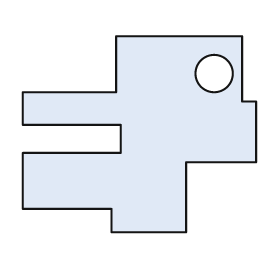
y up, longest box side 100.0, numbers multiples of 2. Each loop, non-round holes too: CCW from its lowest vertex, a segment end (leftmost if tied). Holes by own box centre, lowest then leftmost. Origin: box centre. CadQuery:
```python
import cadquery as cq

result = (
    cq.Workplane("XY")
    .moveTo(-12.0, -42.0)
    .lineTo(20.0, -42.0)
    .lineTo(20.0, -12.0)
    .lineTo(50.0, -12.0)
    .lineTo(50.0, 14.0)
    .lineTo(44.0, 14.0)
    .lineTo(44.0, 42.0)
    .lineTo(-10.0, 42.0)
    .lineTo(-10.0, 18.0)
    .lineTo(-50.0, 18.0)
    .lineTo(-50.0, 4.0)
    .lineTo(-8.0, 4.0)
    .lineTo(-8.0, -8.0)
    .lineTo(-50.0, -8.0)
    .lineTo(-50.0, -32.0)
    .lineTo(-12.0, -32.0)
    .close()
    .moveTo(32.0, 26.0)
    .circle(8.0)
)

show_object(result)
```